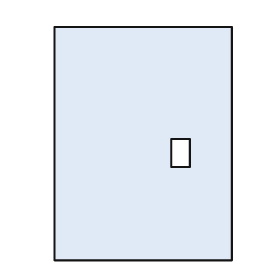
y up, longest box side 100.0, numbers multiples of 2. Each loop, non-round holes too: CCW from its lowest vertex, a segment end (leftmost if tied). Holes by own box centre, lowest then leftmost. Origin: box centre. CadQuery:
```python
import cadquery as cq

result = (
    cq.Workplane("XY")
    .moveTo(-38.0, -50.0)
    .lineTo(38.0, -50.0)
    .lineTo(38.0, 50.0)
    .lineTo(-38.0, 50.0)
    .close()
    .moveTo(12.0, -10.0)
    .lineTo(20.0, -10.0)
    .lineTo(20.0, 2.0)
    .lineTo(12.0, 2.0)
    .close()
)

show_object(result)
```